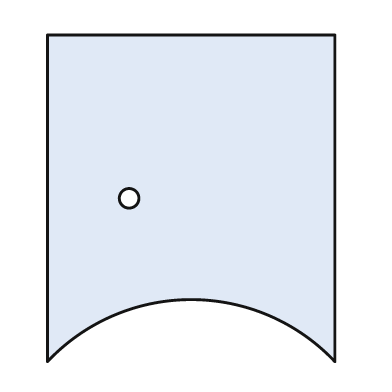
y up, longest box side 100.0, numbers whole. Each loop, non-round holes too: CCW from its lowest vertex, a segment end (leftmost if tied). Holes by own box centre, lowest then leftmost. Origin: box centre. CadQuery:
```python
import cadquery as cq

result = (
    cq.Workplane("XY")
    .moveTo(-44.0, -50.0)
    .threePointArc((0.0, -31.0), (44.0, -50.0))
    .lineTo(44.0, 50.0)
    .lineTo(-44.0, 50.0)
    .close()
    .moveTo(-19.0, 0.0)
    .circle(3.0)
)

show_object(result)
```